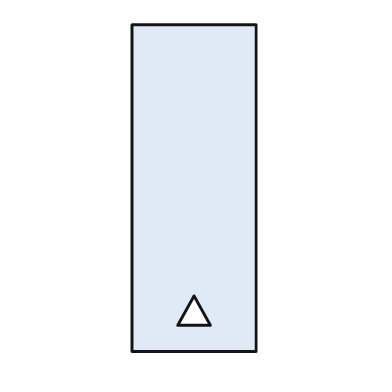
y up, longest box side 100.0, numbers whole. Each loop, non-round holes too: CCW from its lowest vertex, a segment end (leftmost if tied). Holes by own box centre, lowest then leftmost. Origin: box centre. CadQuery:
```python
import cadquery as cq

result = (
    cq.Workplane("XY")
    .moveTo(-19.0, -50.0)
    .lineTo(19.0, -50.0)
    .lineTo(19.0, 50.0)
    .lineTo(-19.0, 50.0)
    .close()
    .moveTo(-5.0, -42.0)
    .lineTo(5.0, -42.0)
    .lineTo(0.0, -33.0)
    .close()
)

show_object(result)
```